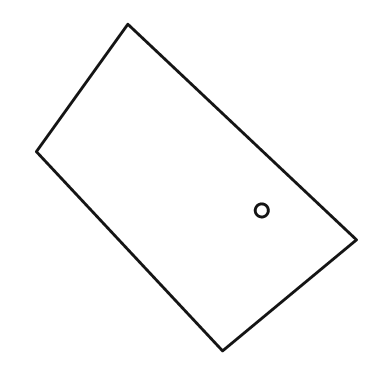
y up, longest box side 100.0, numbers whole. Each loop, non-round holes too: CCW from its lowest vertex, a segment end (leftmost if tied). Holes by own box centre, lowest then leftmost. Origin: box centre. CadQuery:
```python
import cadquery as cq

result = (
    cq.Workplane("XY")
    .moveTo(8.0, -50.0)
    .lineTo(49.0, -16.0)
    .lineTo(-21.0, 50.0)
    .lineTo(-49.0, 11.0)
    .close()
    .moveTo(20.0, -7.0)
    .circle(2.0)
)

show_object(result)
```